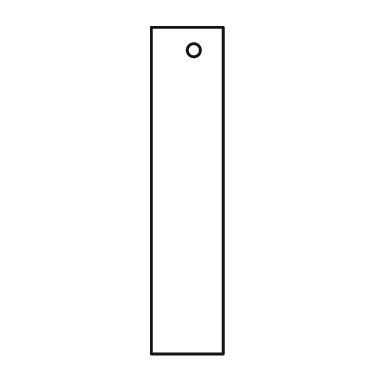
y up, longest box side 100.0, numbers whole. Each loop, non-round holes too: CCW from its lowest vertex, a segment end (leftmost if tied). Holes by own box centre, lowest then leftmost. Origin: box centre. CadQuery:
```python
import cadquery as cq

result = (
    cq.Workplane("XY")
    .moveTo(-11.0, -50.0)
    .lineTo(11.0, -50.0)
    .lineTo(11.0, 50.0)
    .lineTo(-11.0, 50.0)
    .close()
    .moveTo(2.0, 43.0)
    .circle(2.0)
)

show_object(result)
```